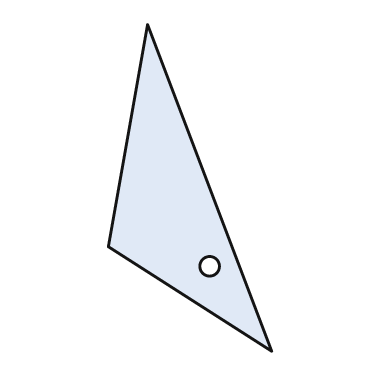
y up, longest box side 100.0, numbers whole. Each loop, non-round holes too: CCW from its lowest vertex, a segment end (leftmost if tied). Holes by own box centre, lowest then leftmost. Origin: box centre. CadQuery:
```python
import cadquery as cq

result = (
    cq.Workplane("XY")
    .moveTo(25.0, -50.0)
    .lineTo(-13.0, 50.0)
    .lineTo(-25.0, -18.0)
    .close()
    .moveTo(6.0, -24.0)
    .circle(3.0)
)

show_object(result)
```